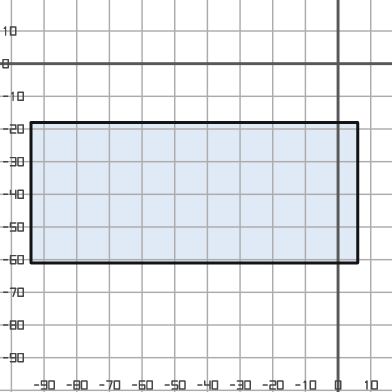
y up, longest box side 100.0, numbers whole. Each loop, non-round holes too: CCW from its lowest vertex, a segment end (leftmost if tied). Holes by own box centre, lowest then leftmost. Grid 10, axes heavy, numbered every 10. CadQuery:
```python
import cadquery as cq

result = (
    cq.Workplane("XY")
    .moveTo(-94.0, -61.0)
    .lineTo(6.0, -61.0)
    .lineTo(6.0, -18.0)
    .lineTo(-94.0, -18.0)
    .close()
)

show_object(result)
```